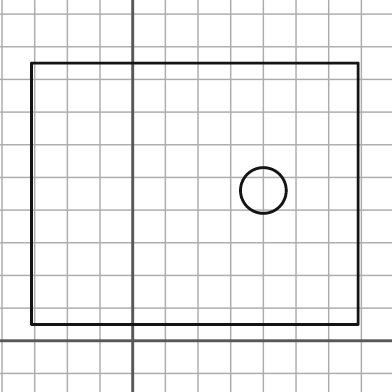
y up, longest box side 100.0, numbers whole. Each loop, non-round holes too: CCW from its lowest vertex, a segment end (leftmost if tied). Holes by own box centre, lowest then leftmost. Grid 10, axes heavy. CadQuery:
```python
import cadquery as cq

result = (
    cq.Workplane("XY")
    .moveTo(-31.0, 5.0)
    .lineTo(69.0, 5.0)
    .lineTo(69.0, 85.0)
    .lineTo(-31.0, 85.0)
    .close()
    .moveTo(40.0, 46.0)
    .circle(7.0)
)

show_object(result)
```